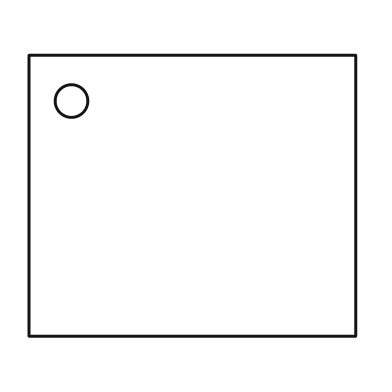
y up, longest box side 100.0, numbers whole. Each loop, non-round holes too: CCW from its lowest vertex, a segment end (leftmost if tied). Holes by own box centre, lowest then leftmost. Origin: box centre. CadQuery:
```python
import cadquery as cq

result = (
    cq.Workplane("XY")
    .moveTo(-50.0, -43.0)
    .lineTo(50.0, -43.0)
    .lineTo(50.0, 43.0)
    .lineTo(-50.0, 43.0)
    .close()
    .moveTo(-37.0, 29.0)
    .circle(5.0)
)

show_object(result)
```